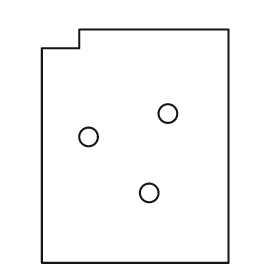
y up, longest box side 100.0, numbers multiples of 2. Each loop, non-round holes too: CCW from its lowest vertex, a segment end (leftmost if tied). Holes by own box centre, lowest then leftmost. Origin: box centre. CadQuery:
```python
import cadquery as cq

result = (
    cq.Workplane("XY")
    .moveTo(-40.0, -50.0)
    .lineTo(40.0, -50.0)
    .lineTo(40.0, 50.0)
    .lineTo(-24.0, 50.0)
    .lineTo(-24.0, 42.0)
    .lineTo(-40.0, 42.0)
    .close()
    .moveTo(6.0, -20.0)
    .circle(4.0)
    .moveTo(-20.0, 4.0)
    .circle(4.0)
    .moveTo(14.0, 14.0)
    .circle(4.0)
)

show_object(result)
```